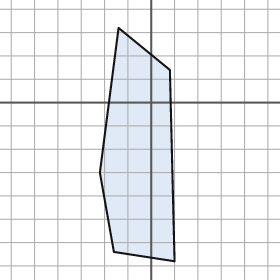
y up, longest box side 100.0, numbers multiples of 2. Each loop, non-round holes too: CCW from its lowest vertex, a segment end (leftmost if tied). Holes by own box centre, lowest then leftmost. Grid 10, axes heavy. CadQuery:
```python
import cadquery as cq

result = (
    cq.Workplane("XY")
    .moveTo(10.0, -68.0)
    .lineTo(8.0, 14.0)
    .lineTo(-14.0, 32.0)
    .lineTo(-22.0, -30.0)
    .lineTo(-16.0, -64.0)
    .close()
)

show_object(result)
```